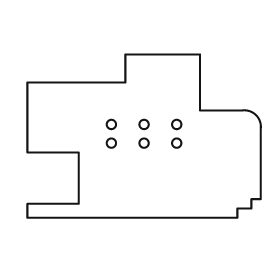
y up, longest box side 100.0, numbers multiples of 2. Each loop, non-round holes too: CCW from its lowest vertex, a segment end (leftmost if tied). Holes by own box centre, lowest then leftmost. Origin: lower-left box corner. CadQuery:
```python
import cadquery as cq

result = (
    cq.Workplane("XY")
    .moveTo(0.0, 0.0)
    .lineTo(90.0, 0.0)
    .lineTo(90.0, 4.0)
    .lineTo(96.0, 4.0)
    .lineTo(96.0, 8.0)
    .lineTo(100.0, 8.0)
    .lineTo(100.0, 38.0)
    .threePointArc((98.0, 44.0), (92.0, 46.0))
    .lineTo(74.0, 46.0)
    .lineTo(74.0, 70.0)
    .lineTo(42.0, 70.0)
    .lineTo(42.0, 58.0)
    .lineTo(0.0, 58.0)
    .lineTo(0.0, 28.0)
    .lineTo(22.0, 28.0)
    .lineTo(22.0, 6.0)
    .lineTo(0.0, 6.0)
    .close()
    .moveTo(36.0, 32.0)
    .circle(2.0)
    .moveTo(50.0, 32.0)
    .circle(2.0)
    .moveTo(64.0, 32.0)
    .circle(2.0)
    .moveTo(36.0, 40.0)
    .circle(2.0)
    .moveTo(50.0, 40.0)
    .circle(2.0)
    .moveTo(64.0, 40.0)
    .circle(2.0)
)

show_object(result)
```